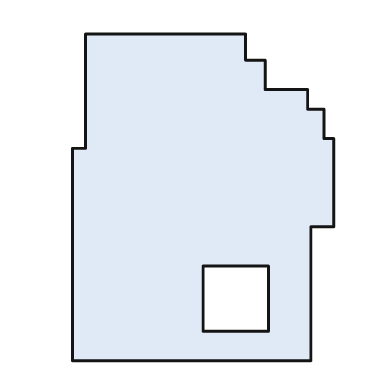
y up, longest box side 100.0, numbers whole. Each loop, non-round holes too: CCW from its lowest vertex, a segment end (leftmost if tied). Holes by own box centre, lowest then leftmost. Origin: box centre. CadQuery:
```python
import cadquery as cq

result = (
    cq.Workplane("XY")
    .moveTo(-40.0, -50.0)
    .lineTo(33.0, -50.0)
    .lineTo(33.0, -9.0)
    .lineTo(40.0, -9.0)
    .lineTo(40.0, 18.0)
    .lineTo(37.0, 18.0)
    .lineTo(37.0, 27.0)
    .lineTo(32.0, 27.0)
    .lineTo(32.0, 33.0)
    .lineTo(19.0, 33.0)
    .lineTo(19.0, 42.0)
    .lineTo(13.0, 42.0)
    .lineTo(13.0, 50.0)
    .lineTo(-36.0, 50.0)
    .lineTo(-36.0, 15.0)
    .lineTo(-40.0, 15.0)
    .close()
    .moveTo(0.0, -41.0)
    .lineTo(20.0, -41.0)
    .lineTo(20.0, -21.0)
    .lineTo(0.0, -21.0)
    .close()
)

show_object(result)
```